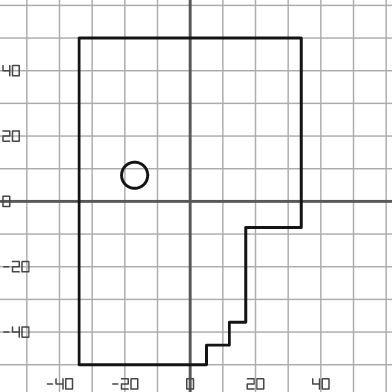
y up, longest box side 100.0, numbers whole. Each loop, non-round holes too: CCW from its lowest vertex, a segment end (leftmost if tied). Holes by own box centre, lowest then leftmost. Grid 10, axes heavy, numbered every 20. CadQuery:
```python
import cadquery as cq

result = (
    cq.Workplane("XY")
    .moveTo(-34.0, -50.0)
    .lineTo(5.0, -50.0)
    .lineTo(5.0, -44.0)
    .lineTo(12.0, -44.0)
    .lineTo(12.0, -37.0)
    .lineTo(17.0, -37.0)
    .lineTo(17.0, -8.0)
    .lineTo(34.0, -8.0)
    .lineTo(34.0, 50.0)
    .lineTo(-34.0, 50.0)
    .close()
    .moveTo(-17.0, 8.0)
    .circle(4.0)
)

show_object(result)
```